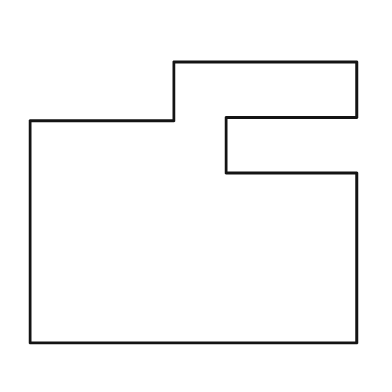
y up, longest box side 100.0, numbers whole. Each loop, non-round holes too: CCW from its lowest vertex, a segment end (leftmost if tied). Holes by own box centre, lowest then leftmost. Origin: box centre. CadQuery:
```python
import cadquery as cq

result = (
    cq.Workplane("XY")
    .moveTo(-50.0, -43.0)
    .lineTo(50.0, -43.0)
    .lineTo(50.0, 9.0)
    .lineTo(10.0, 9.0)
    .lineTo(10.0, 26.0)
    .lineTo(50.0, 26.0)
    .lineTo(50.0, 43.0)
    .lineTo(-6.0, 43.0)
    .lineTo(-6.0, 25.0)
    .lineTo(-50.0, 25.0)
    .close()
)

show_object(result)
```